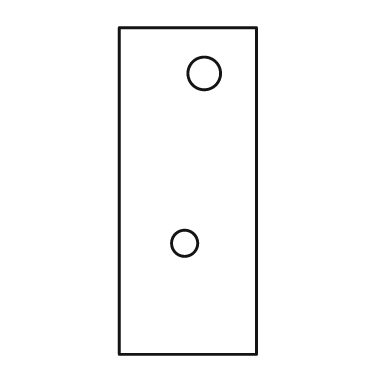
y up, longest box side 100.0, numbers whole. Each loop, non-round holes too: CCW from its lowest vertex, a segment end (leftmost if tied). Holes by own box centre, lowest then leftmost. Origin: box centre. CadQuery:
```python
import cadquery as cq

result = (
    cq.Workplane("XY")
    .moveTo(-21.0, -50.0)
    .lineTo(21.0, -50.0)
    .lineTo(21.0, 50.0)
    .lineTo(-21.0, 50.0)
    .close()
    .moveTo(-1.0, -16.0)
    .circle(4.0)
    .moveTo(5.0, 36.0)
    .circle(5.0)
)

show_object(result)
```